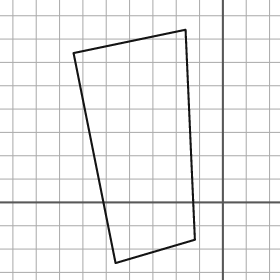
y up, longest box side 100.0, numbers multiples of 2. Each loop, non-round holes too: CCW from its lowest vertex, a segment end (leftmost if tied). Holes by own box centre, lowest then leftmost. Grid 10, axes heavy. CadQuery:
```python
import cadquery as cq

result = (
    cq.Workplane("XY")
    .moveTo(-46.0, -26.0)
    .lineTo(-12.0, -16.0)
    .lineTo(-16.0, 74.0)
    .lineTo(-64.0, 64.0)
    .close()
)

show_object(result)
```